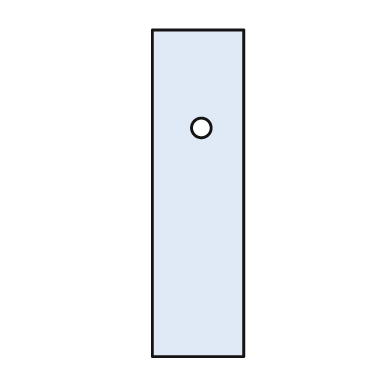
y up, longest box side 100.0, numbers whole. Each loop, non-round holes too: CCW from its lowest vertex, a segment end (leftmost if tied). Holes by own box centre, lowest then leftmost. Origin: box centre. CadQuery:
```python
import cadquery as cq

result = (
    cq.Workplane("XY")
    .moveTo(-14.0, -50.0)
    .lineTo(14.0, -50.0)
    .lineTo(14.0, 50.0)
    .lineTo(-14.0, 50.0)
    .close()
    .moveTo(1.0, 20.0)
    .circle(3.0)
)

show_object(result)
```